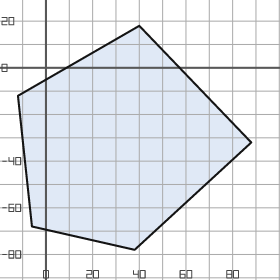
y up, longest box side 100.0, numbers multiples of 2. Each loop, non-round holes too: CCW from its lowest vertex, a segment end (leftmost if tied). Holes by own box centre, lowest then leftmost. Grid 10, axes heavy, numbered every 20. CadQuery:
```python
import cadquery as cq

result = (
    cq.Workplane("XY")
    .moveTo(38.0, -78.0)
    .lineTo(88.0, -32.0)
    .lineTo(40.0, 18.0)
    .lineTo(-12.0, -12.0)
    .lineTo(-6.0, -68.0)
    .close()
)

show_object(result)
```